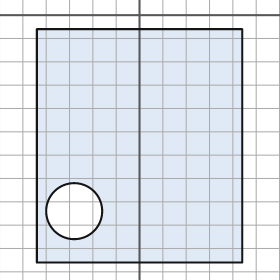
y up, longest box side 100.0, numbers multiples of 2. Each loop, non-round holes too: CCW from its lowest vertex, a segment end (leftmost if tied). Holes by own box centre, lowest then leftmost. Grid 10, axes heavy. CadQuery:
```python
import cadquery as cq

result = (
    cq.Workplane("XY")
    .moveTo(-44.0, -106.0)
    .lineTo(44.0, -106.0)
    .lineTo(44.0, -6.0)
    .lineTo(-44.0, -6.0)
    .close()
    .moveTo(-28.0, -84.0)
    .circle(12.0)
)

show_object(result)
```